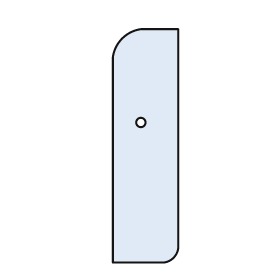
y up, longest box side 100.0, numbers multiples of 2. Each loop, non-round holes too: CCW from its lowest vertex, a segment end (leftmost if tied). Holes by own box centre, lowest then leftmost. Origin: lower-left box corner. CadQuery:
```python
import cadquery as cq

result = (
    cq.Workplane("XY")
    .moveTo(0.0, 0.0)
    .lineTo(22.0, 0.0)
    .threePointArc((26.0, 2.0), (28.0, 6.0))
    .lineTo(28.0, 100.0)
    .lineTo(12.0, 100.0)
    .threePointArc((4.0, 96.0), (0.0, 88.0))
    .close()
    .moveTo(12.0, 60.0)
    .circle(2.0)
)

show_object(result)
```